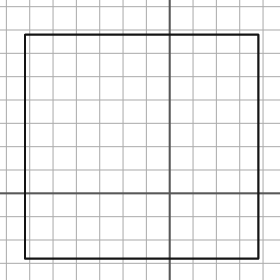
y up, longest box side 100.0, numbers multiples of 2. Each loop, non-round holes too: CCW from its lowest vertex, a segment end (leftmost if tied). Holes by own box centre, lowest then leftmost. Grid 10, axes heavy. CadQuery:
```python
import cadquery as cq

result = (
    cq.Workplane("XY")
    .moveTo(-62.0, -28.0)
    .lineTo(38.0, -28.0)
    .lineTo(38.0, 68.0)
    .lineTo(-62.0, 68.0)
    .close()
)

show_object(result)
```